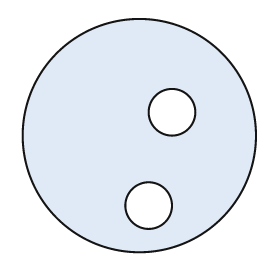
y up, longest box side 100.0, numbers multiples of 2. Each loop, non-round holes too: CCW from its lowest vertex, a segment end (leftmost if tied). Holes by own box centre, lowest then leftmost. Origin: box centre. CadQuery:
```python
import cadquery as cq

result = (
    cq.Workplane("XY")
    .moveTo(0.0, 0.0)
    .circle(50.0)
    .moveTo(4.0, -30.0)
    .circle(10.0)
    .moveTo(14.0, 10.0)
    .circle(10.0)
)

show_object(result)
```